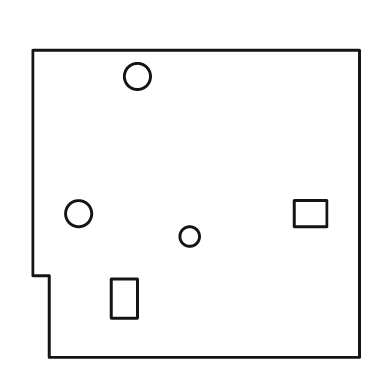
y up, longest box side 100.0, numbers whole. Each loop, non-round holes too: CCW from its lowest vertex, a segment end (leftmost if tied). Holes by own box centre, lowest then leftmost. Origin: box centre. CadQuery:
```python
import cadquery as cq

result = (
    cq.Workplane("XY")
    .moveTo(-45.0, -47.0)
    .lineTo(50.0, -47.0)
    .lineTo(50.0, 47.0)
    .lineTo(-50.0, 47.0)
    .lineTo(-50.0, -22.0)
    .lineTo(-45.0, -22.0)
    .close()
    .moveTo(-26.0, -35.0)
    .lineTo(-18.0, -35.0)
    .lineTo(-18.0, -23.0)
    .lineTo(-26.0, -23.0)
    .close()
    .moveTo(-2.0, -10.0)
    .circle(3.0)
    .moveTo(-36.0, -3.0)
    .circle(4.0)
    .moveTo(30.0, -7.0)
    .lineTo(40.0, -7.0)
    .lineTo(40.0, 1.0)
    .lineTo(30.0, 1.0)
    .close()
    .moveTo(-18.0, 39.0)
    .circle(4.0)
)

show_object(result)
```